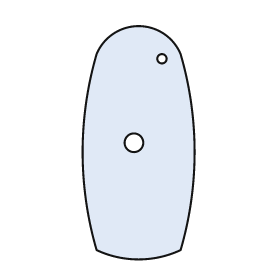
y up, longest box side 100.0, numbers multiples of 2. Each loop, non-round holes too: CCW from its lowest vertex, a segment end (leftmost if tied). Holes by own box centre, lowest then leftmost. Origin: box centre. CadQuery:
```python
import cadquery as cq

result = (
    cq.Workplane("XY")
    .moveTo(-18.0, -46.0)
    .threePointArc((0.0, -50.0), (18.0, -46.0))
    .threePointArc((24.0, -4.0), (18.0, 38.0))
    .threePointArc((0.0, 50.0), (-18.0, 38.0))
    .threePointArc((-24.0, -4.0), (-18.0, -46.0))
    .close()
    .moveTo(-2.0, 0.0)
    .circle(4.0)
    .moveTo(10.0, 36.0)
    .circle(2.0)
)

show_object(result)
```